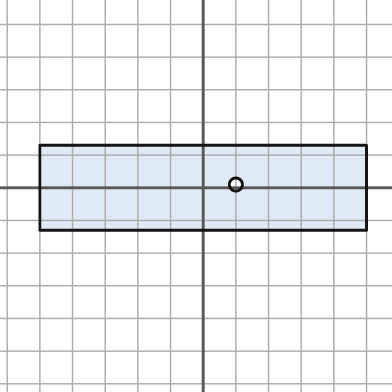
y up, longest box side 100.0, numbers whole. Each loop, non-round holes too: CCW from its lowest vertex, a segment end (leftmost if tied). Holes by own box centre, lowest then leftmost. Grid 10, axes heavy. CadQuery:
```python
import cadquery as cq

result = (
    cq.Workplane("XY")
    .moveTo(-50.0, -13.0)
    .lineTo(50.0, -13.0)
    .lineTo(50.0, 13.0)
    .lineTo(-50.0, 13.0)
    .close()
    .moveTo(10.0, 1.0)
    .circle(2.0)
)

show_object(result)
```